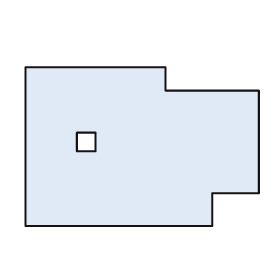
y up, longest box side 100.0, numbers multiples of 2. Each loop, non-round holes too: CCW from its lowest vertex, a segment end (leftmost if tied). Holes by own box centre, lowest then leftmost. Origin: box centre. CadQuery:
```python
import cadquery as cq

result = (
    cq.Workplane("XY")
    .moveTo(-50.0, -34.0)
    .lineTo(30.0, -34.0)
    .lineTo(30.0, -20.0)
    .lineTo(50.0, -20.0)
    .lineTo(50.0, 24.0)
    .lineTo(10.0, 24.0)
    .lineTo(10.0, 34.0)
    .lineTo(-50.0, 34.0)
    .close()
    .moveTo(-28.0, -2.0)
    .lineTo(-20.0, -2.0)
    .lineTo(-20.0, 6.0)
    .lineTo(-28.0, 6.0)
    .close()
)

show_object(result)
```